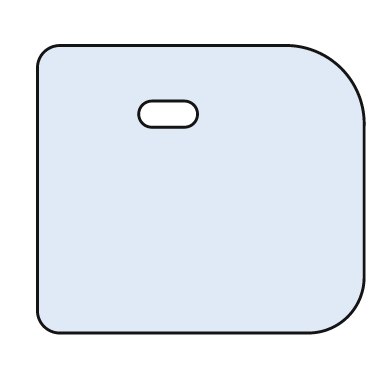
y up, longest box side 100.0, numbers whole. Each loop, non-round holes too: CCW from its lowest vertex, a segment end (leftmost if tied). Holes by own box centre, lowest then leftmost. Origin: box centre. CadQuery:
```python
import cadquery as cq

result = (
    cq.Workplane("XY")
    .moveTo(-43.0, -44.0)
    .lineTo(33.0, -44.0)
    .threePointArc((45.0, -39.0), (50.0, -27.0))
    .lineTo(50.0, 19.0)
    .threePointArc((43.0, 37.0), (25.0, 44.0))
    .lineTo(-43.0, 44.0)
    .threePointArc((-48.0, 42.0), (-50.0, 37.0))
    .lineTo(-50.0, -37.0)
    .threePointArc((-48.0, -42.0), (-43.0, -44.0))
    .close()
    .moveTo(-15.0, 19.0)
    .lineTo(-5.0, 19.0)
    .threePointArc((-1.0, 23.0), (-5.0, 27.0))
    .lineTo(-15.0, 27.0)
    .threePointArc((-19.0, 23.0), (-15.0, 19.0))
    .close()
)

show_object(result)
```